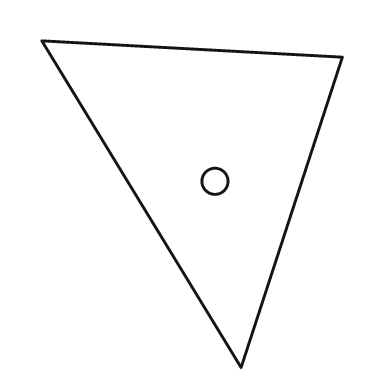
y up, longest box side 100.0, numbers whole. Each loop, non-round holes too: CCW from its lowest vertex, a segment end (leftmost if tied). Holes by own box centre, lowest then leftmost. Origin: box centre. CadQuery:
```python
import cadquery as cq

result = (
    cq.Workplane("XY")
    .moveTo(15.0, -50.0)
    .lineTo(46.0, 45.0)
    .lineTo(-46.0, 50.0)
    .close()
    .moveTo(7.0, 7.0)
    .circle(4.0)
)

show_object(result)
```